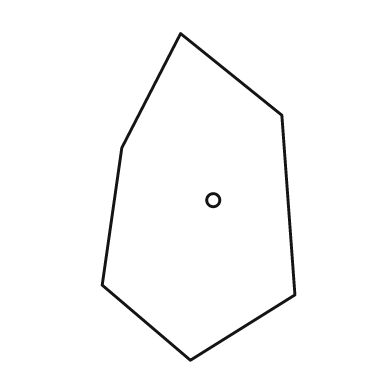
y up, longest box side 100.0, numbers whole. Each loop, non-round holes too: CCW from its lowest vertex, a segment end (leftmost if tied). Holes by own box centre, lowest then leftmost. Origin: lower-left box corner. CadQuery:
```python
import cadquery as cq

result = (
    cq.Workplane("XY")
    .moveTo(27.0, 0.0)
    .lineTo(59.0, 20.0)
    .lineTo(55.0, 75.0)
    .lineTo(24.0, 100.0)
    .lineTo(6.0, 65.0)
    .lineTo(0.0, 23.0)
    .close()
    .moveTo(34.0, 49.0)
    .circle(2.0)
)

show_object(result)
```